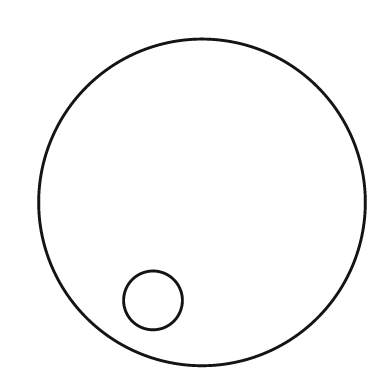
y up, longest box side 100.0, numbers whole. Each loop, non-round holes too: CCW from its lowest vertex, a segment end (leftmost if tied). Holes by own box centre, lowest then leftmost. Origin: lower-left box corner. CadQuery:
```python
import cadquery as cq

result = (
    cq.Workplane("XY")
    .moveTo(50.0, 50.0)
    .circle(50.0)
    .moveTo(35.0, 20.0)
    .circle(9.0)
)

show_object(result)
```